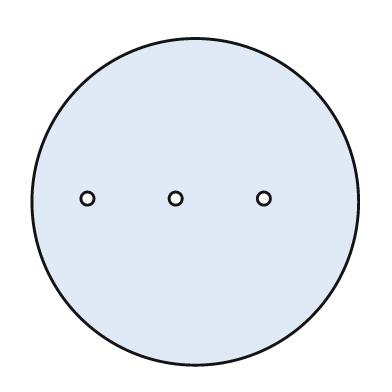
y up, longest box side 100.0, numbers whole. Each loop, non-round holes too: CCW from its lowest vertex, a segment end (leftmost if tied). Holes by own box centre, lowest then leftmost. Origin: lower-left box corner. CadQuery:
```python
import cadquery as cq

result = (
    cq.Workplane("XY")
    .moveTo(50.0, 50.0)
    .circle(50.0)
    .moveTo(17.0, 51.0)
    .circle(2.0)
    .moveTo(44.0, 51.0)
    .circle(2.0)
    .moveTo(71.0, 51.0)
    .circle(2.0)
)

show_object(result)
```